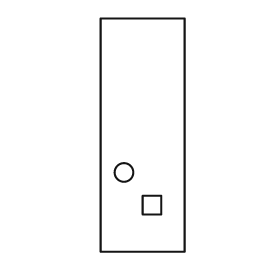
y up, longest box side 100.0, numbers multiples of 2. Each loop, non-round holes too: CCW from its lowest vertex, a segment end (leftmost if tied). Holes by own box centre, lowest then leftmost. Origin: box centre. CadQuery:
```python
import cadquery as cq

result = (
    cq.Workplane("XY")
    .moveTo(-18.0, -50.0)
    .lineTo(18.0, -50.0)
    .lineTo(18.0, 50.0)
    .lineTo(-18.0, 50.0)
    .close()
    .moveTo(0.0, -34.0)
    .lineTo(8.0, -34.0)
    .lineTo(8.0, -26.0)
    .lineTo(0.0, -26.0)
    .close()
    .moveTo(-8.0, -16.0)
    .circle(4.0)
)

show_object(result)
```